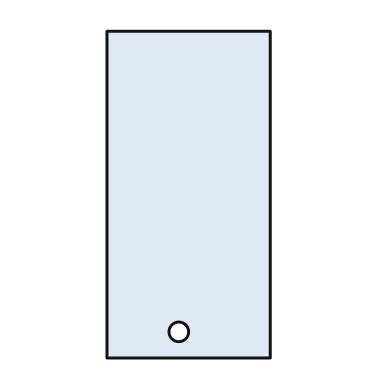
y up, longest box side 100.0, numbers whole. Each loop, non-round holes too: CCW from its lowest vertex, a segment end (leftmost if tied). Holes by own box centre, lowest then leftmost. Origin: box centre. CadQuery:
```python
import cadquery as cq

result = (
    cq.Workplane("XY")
    .moveTo(-25.0, -50.0)
    .lineTo(25.0, -50.0)
    .lineTo(25.0, 50.0)
    .lineTo(-25.0, 50.0)
    .close()
    .moveTo(-3.0, -42.0)
    .circle(3.0)
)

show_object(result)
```